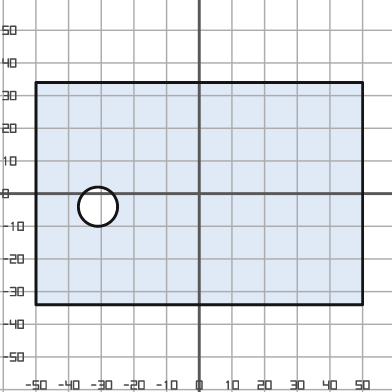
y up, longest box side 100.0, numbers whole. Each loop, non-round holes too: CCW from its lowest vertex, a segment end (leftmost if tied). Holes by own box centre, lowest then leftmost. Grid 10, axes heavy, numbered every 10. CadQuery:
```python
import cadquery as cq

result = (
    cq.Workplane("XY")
    .moveTo(-50.0, -34.0)
    .lineTo(50.0, -34.0)
    .lineTo(50.0, 34.0)
    .lineTo(-50.0, 34.0)
    .close()
    .moveTo(-31.0, -4.0)
    .circle(6.0)
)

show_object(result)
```